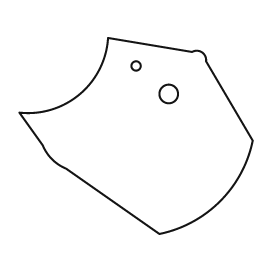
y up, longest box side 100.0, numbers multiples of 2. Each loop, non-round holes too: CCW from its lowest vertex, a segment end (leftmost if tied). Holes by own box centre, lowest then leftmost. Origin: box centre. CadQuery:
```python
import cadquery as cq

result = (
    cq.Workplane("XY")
    .moveTo(10.0, -42.0)
    .threePointArc((36.0, -28.0), (50.0, -2.0))
    .lineTo(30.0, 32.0)
    .threePointArc((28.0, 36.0), (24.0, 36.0))
    .lineTo(-12.0, 42.0)
    .threePointArc((-24.0, 18.0), (-50.0, 10.0))
    .lineTo(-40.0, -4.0)
    .threePointArc((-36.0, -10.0), (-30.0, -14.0))
    .close()
    .moveTo(14.0, 18.0)
    .circle(4.0)
    .moveTo(0.0, 30.0)
    .circle(2.0)
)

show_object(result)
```